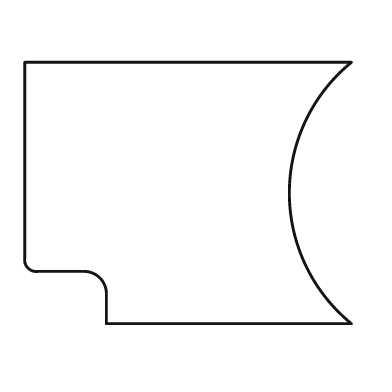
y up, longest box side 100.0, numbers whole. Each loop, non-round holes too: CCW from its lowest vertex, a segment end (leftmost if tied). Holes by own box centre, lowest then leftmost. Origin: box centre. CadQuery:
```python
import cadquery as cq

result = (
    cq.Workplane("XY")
    .moveTo(-25.0, -40.0)
    .lineTo(50.0, -40.0)
    .threePointArc((31.0, 0.0), (50.0, 40.0))
    .lineTo(-50.0, 40.0)
    .lineTo(-50.0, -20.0)
    .threePointArc((-49.0, -23.0), (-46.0, -24.0))
    .lineTo(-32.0, -24.0)
    .threePointArc((-27.0, -26.0), (-25.0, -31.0))
    .close()
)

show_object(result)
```